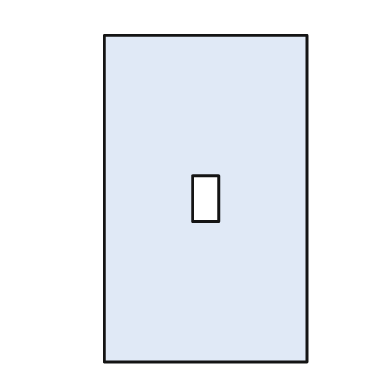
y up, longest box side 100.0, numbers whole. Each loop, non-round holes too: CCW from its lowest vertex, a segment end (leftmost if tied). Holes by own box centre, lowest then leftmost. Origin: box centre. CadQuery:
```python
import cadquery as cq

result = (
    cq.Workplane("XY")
    .moveTo(-31.0, -50.0)
    .lineTo(31.0, -50.0)
    .lineTo(31.0, 50.0)
    .lineTo(-31.0, 50.0)
    .close()
    .moveTo(-4.0, -7.0)
    .lineTo(4.0, -7.0)
    .lineTo(4.0, 7.0)
    .lineTo(-4.0, 7.0)
    .close()
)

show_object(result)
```